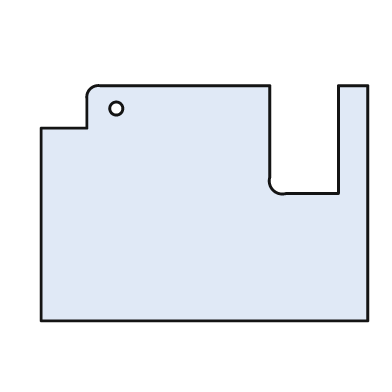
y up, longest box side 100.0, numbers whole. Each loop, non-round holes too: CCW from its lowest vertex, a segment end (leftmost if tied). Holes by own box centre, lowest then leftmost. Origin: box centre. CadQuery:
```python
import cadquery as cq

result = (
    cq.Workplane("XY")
    .moveTo(-50.0, -36.0)
    .lineTo(50.0, -36.0)
    .lineTo(50.0, 36.0)
    .lineTo(41.0, 36.0)
    .lineTo(41.0, 3.0)
    .lineTo(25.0, 3.0)
    .threePointArc((21.0, 4.0), (20.0, 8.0))
    .lineTo(20.0, 36.0)
    .lineTo(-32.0, 36.0)
    .threePointArc((-35.0, 35.0), (-36.0, 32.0))
    .lineTo(-36.0, 23.0)
    .lineTo(-50.0, 23.0)
    .close()
    .moveTo(-27.0, 29.0)
    .circle(2.0)
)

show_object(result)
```